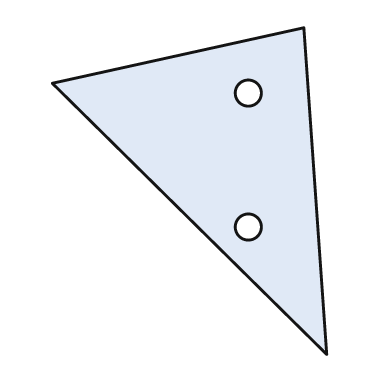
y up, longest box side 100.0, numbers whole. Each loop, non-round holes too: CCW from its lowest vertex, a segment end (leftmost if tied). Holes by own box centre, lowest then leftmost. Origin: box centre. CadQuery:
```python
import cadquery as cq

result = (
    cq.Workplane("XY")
    .moveTo(42.0, -50.0)
    .lineTo(35.0, 50.0)
    .lineTo(-42.0, 33.0)
    .close()
    .moveTo(18.0, -11.0)
    .circle(4.0)
    .moveTo(18.0, 30.0)
    .circle(4.0)
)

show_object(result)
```